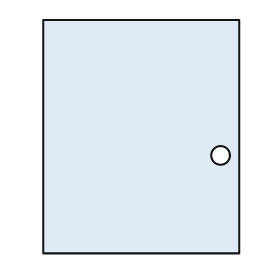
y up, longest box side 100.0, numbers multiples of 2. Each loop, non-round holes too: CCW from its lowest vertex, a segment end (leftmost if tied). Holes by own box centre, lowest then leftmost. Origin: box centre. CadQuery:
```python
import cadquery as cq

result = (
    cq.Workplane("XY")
    .moveTo(-42.0, -50.0)
    .lineTo(42.0, -50.0)
    .lineTo(42.0, 50.0)
    .lineTo(-42.0, 50.0)
    .close()
    .moveTo(34.0, -8.0)
    .circle(4.0)
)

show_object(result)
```